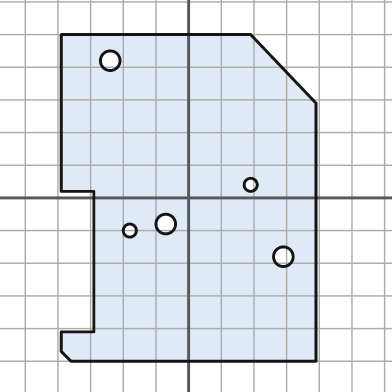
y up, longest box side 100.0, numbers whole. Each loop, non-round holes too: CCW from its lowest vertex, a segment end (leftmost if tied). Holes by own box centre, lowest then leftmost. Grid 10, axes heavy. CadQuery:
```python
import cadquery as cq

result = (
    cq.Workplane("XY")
    .moveTo(-36.0, -50.0)
    .lineTo(39.0, -50.0)
    .lineTo(39.0, 29.0)
    .lineTo(19.0, 50.0)
    .lineTo(-39.0, 50.0)
    .lineTo(-39.0, 2.0)
    .lineTo(-29.0, 2.0)
    .lineTo(-29.0, -41.0)
    .lineTo(-39.0, -41.0)
    .lineTo(-39.0, -47.0)
    .close()
    .moveTo(29.0, -18.0)
    .circle(3.0)
    .moveTo(-18.0, -10.0)
    .circle(2.0)
    .moveTo(-7.0, -8.0)
    .circle(3.0)
    .moveTo(19.0, 4.0)
    .circle(2.0)
    .moveTo(-24.0, 42.0)
    .circle(3.0)
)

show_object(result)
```